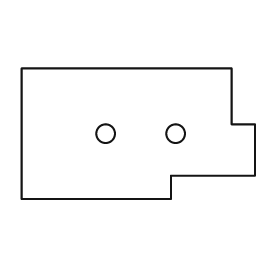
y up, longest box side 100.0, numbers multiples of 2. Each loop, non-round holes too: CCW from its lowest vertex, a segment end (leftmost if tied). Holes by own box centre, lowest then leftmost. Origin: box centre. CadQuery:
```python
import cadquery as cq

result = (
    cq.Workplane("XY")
    .moveTo(-50.0, -28.0)
    .lineTo(14.0, -28.0)
    .lineTo(14.0, -18.0)
    .lineTo(50.0, -18.0)
    .lineTo(50.0, 4.0)
    .lineTo(40.0, 4.0)
    .lineTo(40.0, 28.0)
    .lineTo(-50.0, 28.0)
    .close()
    .moveTo(-14.0, 0.0)
    .circle(4.0)
    .moveTo(16.0, 0.0)
    .circle(4.0)
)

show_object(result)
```